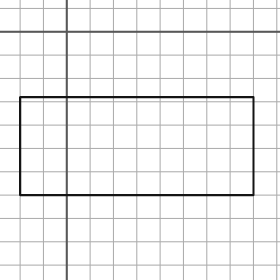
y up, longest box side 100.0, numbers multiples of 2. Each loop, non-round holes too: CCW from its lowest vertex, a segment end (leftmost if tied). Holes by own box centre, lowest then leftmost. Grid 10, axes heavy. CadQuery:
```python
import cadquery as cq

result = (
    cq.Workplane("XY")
    .moveTo(-20.0, -70.0)
    .lineTo(80.0, -70.0)
    .lineTo(80.0, -28.0)
    .lineTo(-20.0, -28.0)
    .close()
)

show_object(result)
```